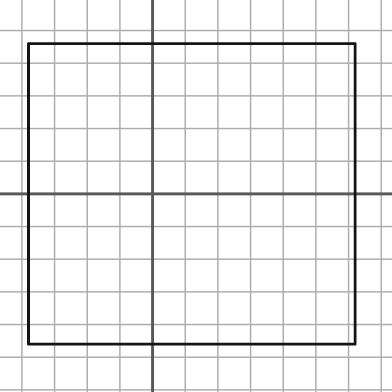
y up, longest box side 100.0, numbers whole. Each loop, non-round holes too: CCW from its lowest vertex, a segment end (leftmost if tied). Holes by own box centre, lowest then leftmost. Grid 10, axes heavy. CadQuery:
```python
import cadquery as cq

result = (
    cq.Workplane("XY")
    .moveTo(-38.0, -46.0)
    .lineTo(62.0, -46.0)
    .lineTo(62.0, 46.0)
    .lineTo(-38.0, 46.0)
    .close()
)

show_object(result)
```